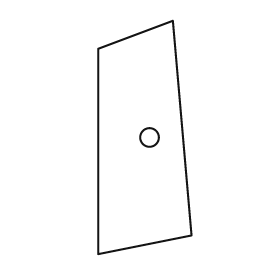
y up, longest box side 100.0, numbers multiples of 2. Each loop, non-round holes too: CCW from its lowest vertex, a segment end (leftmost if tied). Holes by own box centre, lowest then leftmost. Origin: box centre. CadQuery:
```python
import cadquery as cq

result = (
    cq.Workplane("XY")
    .moveTo(-20.0, -50.0)
    .lineTo(20.0, -42.0)
    .lineTo(12.0, 50.0)
    .lineTo(-20.0, 38.0)
    .close()
    .moveTo(2.0, 0.0)
    .circle(4.0)
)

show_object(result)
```